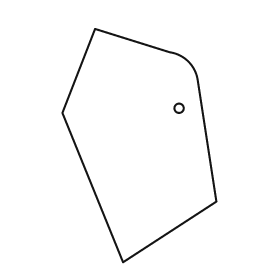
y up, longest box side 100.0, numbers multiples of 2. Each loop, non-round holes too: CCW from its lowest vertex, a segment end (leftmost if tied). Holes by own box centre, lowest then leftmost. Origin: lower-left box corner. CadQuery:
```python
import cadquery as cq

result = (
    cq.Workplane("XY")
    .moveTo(26.0, 0.0)
    .lineTo(66.0, 26.0)
    .lineTo(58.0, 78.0)
    .threePointArc((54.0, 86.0), (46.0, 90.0))
    .lineTo(14.0, 100.0)
    .lineTo(0.0, 64.0)
    .close()
    .moveTo(50.0, 66.0)
    .circle(2.0)
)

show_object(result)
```